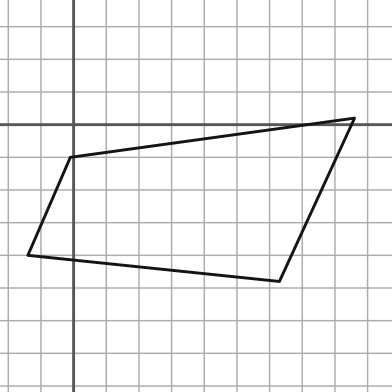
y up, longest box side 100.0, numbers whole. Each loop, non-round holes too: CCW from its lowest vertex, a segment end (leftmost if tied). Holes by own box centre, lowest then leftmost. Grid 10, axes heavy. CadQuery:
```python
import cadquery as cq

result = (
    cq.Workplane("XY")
    .moveTo(63.0, -48.0)
    .lineTo(86.0, 2.0)
    .lineTo(-1.0, -10.0)
    .lineTo(-14.0, -40.0)
    .close()
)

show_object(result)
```